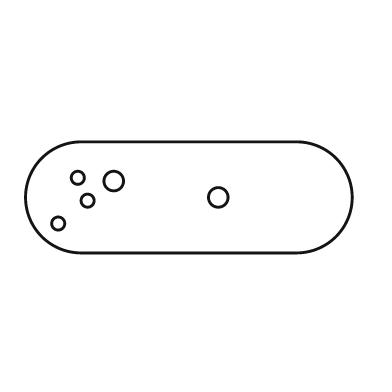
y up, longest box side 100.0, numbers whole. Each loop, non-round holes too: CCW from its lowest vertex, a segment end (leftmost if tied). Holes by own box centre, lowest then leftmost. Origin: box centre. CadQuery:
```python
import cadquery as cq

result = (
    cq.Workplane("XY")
    .moveTo(-33.0, -17.0)
    .lineTo(33.0, -17.0)
    .threePointArc((50.0, 0.0), (33.0, 17.0))
    .lineTo(-33.0, 17.0)
    .threePointArc((-50.0, 0.0), (-33.0, -17.0))
    .close()
    .moveTo(-40.0, -8.0)
    .circle(2.0)
    .moveTo(-31.0, -1.0)
    .circle(2.0)
    .moveTo(9.0, 0.0)
    .circle(3.0)
    .moveTo(-23.0, 5.0)
    .circle(3.0)
    .moveTo(-34.0, 6.0)
    .circle(2.0)
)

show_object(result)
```